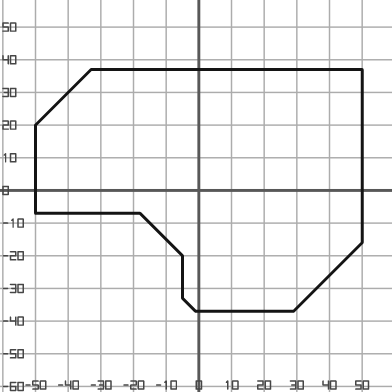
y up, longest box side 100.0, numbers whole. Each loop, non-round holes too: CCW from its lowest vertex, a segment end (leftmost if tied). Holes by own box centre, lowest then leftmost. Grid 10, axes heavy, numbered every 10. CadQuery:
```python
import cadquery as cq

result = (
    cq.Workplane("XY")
    .moveTo(-1.0, -37.0)
    .lineTo(29.0, -37.0)
    .lineTo(50.0, -16.0)
    .lineTo(50.0, 37.0)
    .lineTo(-33.0, 37.0)
    .lineTo(-50.0, 20.0)
    .lineTo(-50.0, -7.0)
    .lineTo(-18.0, -7.0)
    .lineTo(-5.0, -20.0)
    .lineTo(-5.0, -33.0)
    .close()
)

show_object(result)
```